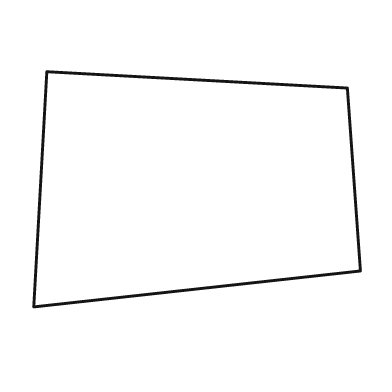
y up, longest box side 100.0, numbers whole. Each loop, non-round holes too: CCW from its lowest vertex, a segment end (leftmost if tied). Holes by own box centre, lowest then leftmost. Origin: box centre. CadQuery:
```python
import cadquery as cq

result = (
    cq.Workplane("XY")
    .moveTo(-50.0, -36.0)
    .lineTo(50.0, -25.0)
    .lineTo(46.0, 31.0)
    .lineTo(-46.0, 36.0)
    .close()
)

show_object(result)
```